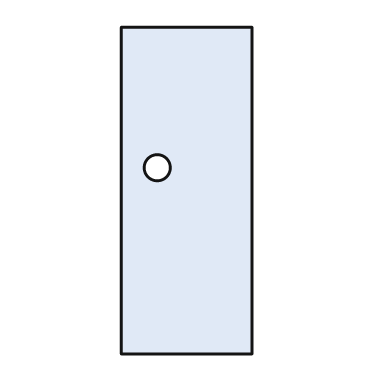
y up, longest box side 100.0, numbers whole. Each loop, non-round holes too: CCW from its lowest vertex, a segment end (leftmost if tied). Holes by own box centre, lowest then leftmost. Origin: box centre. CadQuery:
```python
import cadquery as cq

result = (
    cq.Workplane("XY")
    .moveTo(-20.0, -50.0)
    .lineTo(20.0, -50.0)
    .lineTo(20.0, 50.0)
    .lineTo(-20.0, 50.0)
    .close()
    .moveTo(-9.0, 7.0)
    .circle(4.0)
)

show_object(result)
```